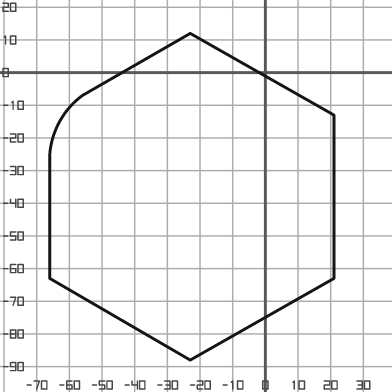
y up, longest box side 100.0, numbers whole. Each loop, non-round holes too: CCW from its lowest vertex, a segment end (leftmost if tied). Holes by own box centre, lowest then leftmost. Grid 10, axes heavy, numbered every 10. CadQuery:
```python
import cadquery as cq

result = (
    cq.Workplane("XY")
    .moveTo(-23.0, -88.0)
    .lineTo(21.0, -63.0)
    .lineTo(21.0, -13.0)
    .lineTo(-23.0, 12.0)
    .lineTo(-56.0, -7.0)
    .threePointArc((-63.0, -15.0), (-66.0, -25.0))
    .lineTo(-66.0, -63.0)
    .close()
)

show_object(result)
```